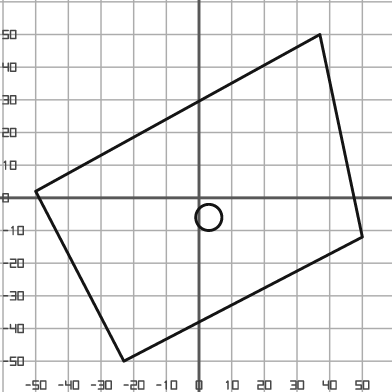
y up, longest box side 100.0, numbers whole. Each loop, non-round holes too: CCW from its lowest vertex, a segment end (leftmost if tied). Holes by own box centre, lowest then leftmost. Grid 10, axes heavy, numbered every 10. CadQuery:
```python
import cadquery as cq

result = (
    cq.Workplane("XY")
    .moveTo(-23.0, -50.0)
    .lineTo(50.0, -12.0)
    .lineTo(37.0, 50.0)
    .lineTo(-50.0, 2.0)
    .close()
    .moveTo(3.0, -6.0)
    .circle(4.0)
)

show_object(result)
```